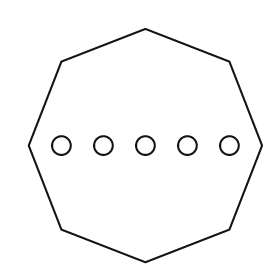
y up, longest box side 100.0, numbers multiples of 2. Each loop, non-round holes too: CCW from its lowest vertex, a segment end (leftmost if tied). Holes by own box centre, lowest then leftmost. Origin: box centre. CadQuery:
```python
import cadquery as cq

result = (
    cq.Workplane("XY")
    .moveTo(0.0, -50.0)
    .lineTo(36.0, -36.0)
    .lineTo(50.0, 0.0)
    .lineTo(36.0, 36.0)
    .lineTo(0.0, 50.0)
    .lineTo(-36.0, 36.0)
    .lineTo(-50.0, 0.0)
    .lineTo(-36.0, -36.0)
    .close()
    .moveTo(-36.0, 0.0)
    .circle(4.0)
    .moveTo(-18.0, 0.0)
    .circle(4.0)
    .moveTo(0.0, 0.0)
    .circle(4.0)
    .moveTo(18.0, 0.0)
    .circle(4.0)
    .moveTo(36.0, 0.0)
    .circle(4.0)
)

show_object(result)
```